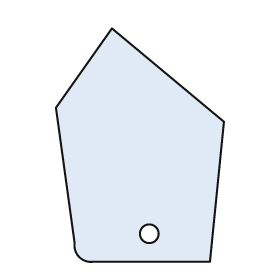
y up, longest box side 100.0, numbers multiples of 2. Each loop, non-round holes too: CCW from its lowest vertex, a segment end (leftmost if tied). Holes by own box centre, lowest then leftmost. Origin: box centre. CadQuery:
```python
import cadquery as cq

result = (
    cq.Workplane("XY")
    .moveTo(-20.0, -50.0)
    .lineTo(30.0, -50.0)
    .lineTo(36.0, 10.0)
    .lineTo(-12.0, 50.0)
    .lineTo(-36.0, 16.0)
    .lineTo(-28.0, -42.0)
    .threePointArc((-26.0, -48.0), (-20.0, -50.0))
    .close()
    .moveTo(4.0, -38.0)
    .circle(4.0)
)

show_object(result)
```